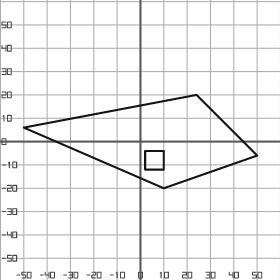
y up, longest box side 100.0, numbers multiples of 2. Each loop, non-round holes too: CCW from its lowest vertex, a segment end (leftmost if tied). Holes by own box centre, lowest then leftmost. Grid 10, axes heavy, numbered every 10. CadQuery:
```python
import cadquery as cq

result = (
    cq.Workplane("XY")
    .moveTo(10.0, -20.0)
    .lineTo(50.0, -6.0)
    .lineTo(24.0, 20.0)
    .lineTo(-50.0, 6.0)
    .close()
    .moveTo(2.0, -12.0)
    .lineTo(10.0, -12.0)
    .lineTo(10.0, -4.0)
    .lineTo(2.0, -4.0)
    .close()
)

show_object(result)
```